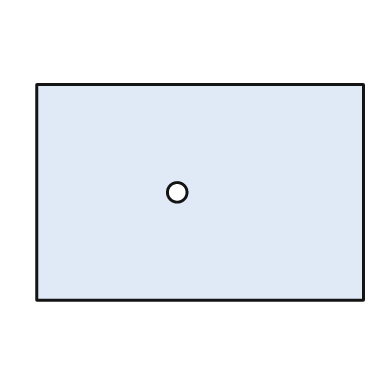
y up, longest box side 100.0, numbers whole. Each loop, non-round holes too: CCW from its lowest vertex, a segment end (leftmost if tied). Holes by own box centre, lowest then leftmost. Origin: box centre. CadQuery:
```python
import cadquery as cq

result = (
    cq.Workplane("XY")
    .moveTo(-50.0, -33.0)
    .lineTo(50.0, -33.0)
    .lineTo(50.0, 33.0)
    .lineTo(-50.0, 33.0)
    .close()
    .moveTo(-7.0, 0.0)
    .circle(3.0)
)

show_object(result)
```